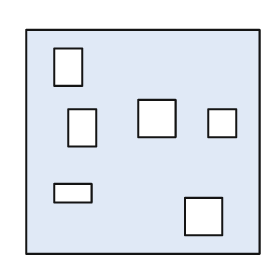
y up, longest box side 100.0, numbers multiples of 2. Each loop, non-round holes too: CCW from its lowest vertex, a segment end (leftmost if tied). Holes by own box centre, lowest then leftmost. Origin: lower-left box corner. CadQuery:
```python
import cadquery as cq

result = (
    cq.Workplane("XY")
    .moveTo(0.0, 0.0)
    .lineTo(100.0, 0.0)
    .lineTo(100.0, 96.0)
    .lineTo(0.0, 96.0)
    .close()
    .moveTo(68.0, 8.0)
    .lineTo(84.0, 8.0)
    .lineTo(84.0, 24.0)
    .lineTo(68.0, 24.0)
    .close()
    .moveTo(12.0, 22.0)
    .lineTo(28.0, 22.0)
    .lineTo(28.0, 30.0)
    .lineTo(12.0, 30.0)
    .close()
    .moveTo(18.0, 46.0)
    .lineTo(30.0, 46.0)
    .lineTo(30.0, 62.0)
    .lineTo(18.0, 62.0)
    .close()
    .moveTo(78.0, 50.0)
    .lineTo(90.0, 50.0)
    .lineTo(90.0, 62.0)
    .lineTo(78.0, 62.0)
    .close()
    .moveTo(48.0, 50.0)
    .lineTo(64.0, 50.0)
    .lineTo(64.0, 66.0)
    .lineTo(48.0, 66.0)
    .close()
    .moveTo(12.0, 72.0)
    .lineTo(24.0, 72.0)
    .lineTo(24.0, 88.0)
    .lineTo(12.0, 88.0)
    .close()
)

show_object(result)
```